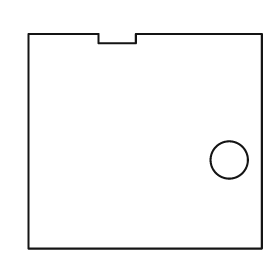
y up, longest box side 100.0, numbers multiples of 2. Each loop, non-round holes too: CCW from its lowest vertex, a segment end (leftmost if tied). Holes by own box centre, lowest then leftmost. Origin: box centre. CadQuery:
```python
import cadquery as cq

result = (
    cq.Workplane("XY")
    .moveTo(-50.0, -46.0)
    .lineTo(50.0, -46.0)
    .lineTo(50.0, 46.0)
    .lineTo(-4.0, 46.0)
    .lineTo(-4.0, 42.0)
    .lineTo(-20.0, 42.0)
    .lineTo(-20.0, 46.0)
    .lineTo(-50.0, 46.0)
    .close()
    .moveTo(36.0, -8.0)
    .circle(8.0)
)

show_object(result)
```